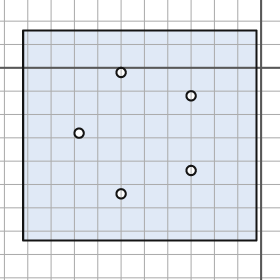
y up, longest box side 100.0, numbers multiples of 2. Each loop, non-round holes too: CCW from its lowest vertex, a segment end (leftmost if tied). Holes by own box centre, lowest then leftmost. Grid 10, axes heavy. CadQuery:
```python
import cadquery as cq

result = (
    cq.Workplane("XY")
    .moveTo(-102.0, -74.0)
    .lineTo(-2.0, -74.0)
    .lineTo(-2.0, 16.0)
    .lineTo(-102.0, 16.0)
    .close()
    .moveTo(-60.0, -54.0)
    .circle(2.0)
    .moveTo(-30.0, -44.0)
    .circle(2.0)
    .moveTo(-78.0, -28.0)
    .circle(2.0)
    .moveTo(-30.0, -12.0)
    .circle(2.0)
    .moveTo(-60.0, -2.0)
    .circle(2.0)
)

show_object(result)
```